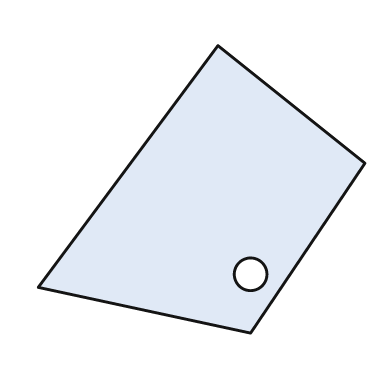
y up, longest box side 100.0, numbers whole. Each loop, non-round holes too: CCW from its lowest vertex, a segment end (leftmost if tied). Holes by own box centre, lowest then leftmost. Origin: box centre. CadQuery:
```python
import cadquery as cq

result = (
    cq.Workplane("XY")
    .moveTo(15.0, -44.0)
    .lineTo(50.0, 8.0)
    .lineTo(5.0, 44.0)
    .lineTo(-50.0, -30.0)
    .close()
    .moveTo(15.0, -26.0)
    .circle(5.0)
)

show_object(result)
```